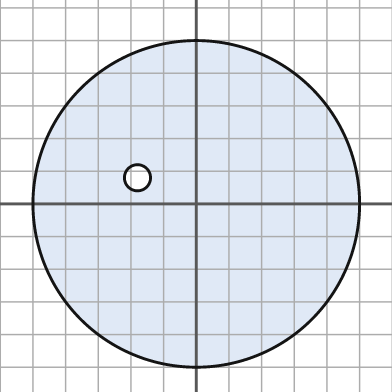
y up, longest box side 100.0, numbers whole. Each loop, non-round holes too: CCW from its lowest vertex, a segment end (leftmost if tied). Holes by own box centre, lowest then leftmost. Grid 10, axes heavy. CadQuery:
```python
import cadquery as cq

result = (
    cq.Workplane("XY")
    .moveTo(0.0, 0.0)
    .circle(50.0)
    .moveTo(-18.0, 8.0)
    .circle(4.0)
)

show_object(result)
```